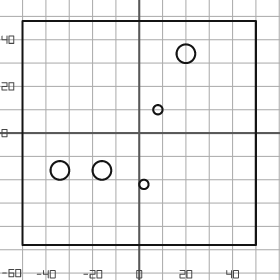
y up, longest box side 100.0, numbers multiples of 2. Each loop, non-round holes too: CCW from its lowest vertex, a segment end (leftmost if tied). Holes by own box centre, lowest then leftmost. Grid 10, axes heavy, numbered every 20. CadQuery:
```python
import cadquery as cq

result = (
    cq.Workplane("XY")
    .moveTo(-50.0, -48.0)
    .lineTo(50.0, -48.0)
    .lineTo(50.0, 48.0)
    .lineTo(-50.0, 48.0)
    .close()
    .moveTo(2.0, -22.0)
    .circle(2.0)
    .moveTo(-34.0, -16.0)
    .circle(4.0)
    .moveTo(-16.0, -16.0)
    .circle(4.0)
    .moveTo(8.0, 10.0)
    .circle(2.0)
    .moveTo(20.0, 34.0)
    .circle(4.0)
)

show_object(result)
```